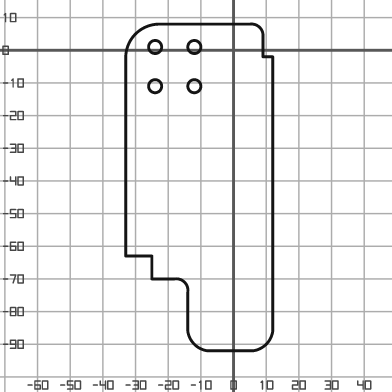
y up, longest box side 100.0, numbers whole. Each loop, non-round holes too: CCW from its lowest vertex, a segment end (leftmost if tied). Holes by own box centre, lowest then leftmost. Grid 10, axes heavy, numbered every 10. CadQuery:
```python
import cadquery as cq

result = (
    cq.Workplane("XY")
    .moveTo(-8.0, -92.0)
    .lineTo(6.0, -92.0)
    .threePointArc((10.0, -90.0), (12.0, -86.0))
    .lineTo(12.0, -2.0)
    .lineTo(9.0, -2.0)
    .lineTo(9.0, 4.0)
    .threePointArc((8.0, 7.0), (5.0, 8.0))
    .lineTo(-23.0, 8.0)
    .threePointArc((-30.0, 5.0), (-33.0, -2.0))
    .lineTo(-33.0, -63.0)
    .lineTo(-25.0, -63.0)
    .lineTo(-25.0, -70.0)
    .lineTo(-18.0, -70.0)
    .threePointArc((-15.0, -71.0), (-14.0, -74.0))
    .lineTo(-14.0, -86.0)
    .threePointArc((-12.0, -90.0), (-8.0, -92.0))
    .close()
    .moveTo(-24.0, -11.0)
    .circle(2.0)
    .moveTo(-12.0, -11.0)
    .circle(2.0)
    .moveTo(-24.0, 1.0)
    .circle(2.0)
    .moveTo(-12.0, 1.0)
    .circle(2.0)
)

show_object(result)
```